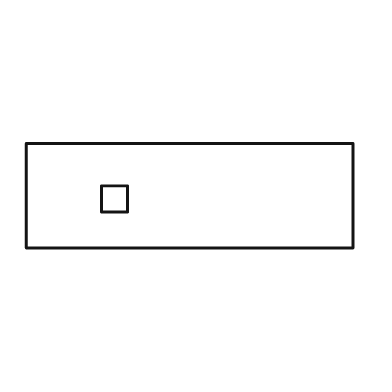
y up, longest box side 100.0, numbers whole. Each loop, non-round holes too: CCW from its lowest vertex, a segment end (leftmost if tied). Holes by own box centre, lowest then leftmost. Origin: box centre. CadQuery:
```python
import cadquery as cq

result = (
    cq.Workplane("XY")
    .moveTo(-50.0, -16.0)
    .lineTo(50.0, -16.0)
    .lineTo(50.0, 16.0)
    .lineTo(-50.0, 16.0)
    .close()
    .moveTo(-27.0, -5.0)
    .lineTo(-19.0, -5.0)
    .lineTo(-19.0, 3.0)
    .lineTo(-27.0, 3.0)
    .close()
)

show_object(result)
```